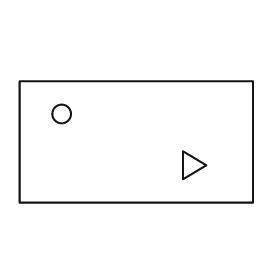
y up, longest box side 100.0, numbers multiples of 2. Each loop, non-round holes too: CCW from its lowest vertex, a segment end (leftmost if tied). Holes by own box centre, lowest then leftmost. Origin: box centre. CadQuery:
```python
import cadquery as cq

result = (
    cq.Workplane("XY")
    .moveTo(-50.0, -26.0)
    .lineTo(50.0, -26.0)
    .lineTo(50.0, 26.0)
    .lineTo(-50.0, 26.0)
    .close()
    .moveTo(20.0, -16.0)
    .lineTo(30.0, -10.0)
    .lineTo(20.0, -4.0)
    .close()
    .moveTo(-32.0, 12.0)
    .circle(4.0)
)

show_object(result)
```